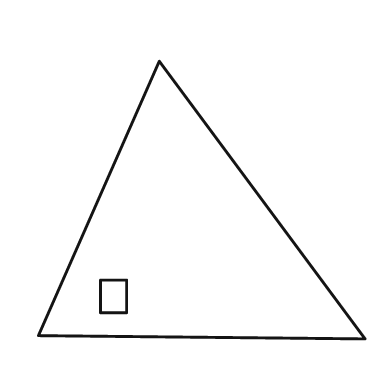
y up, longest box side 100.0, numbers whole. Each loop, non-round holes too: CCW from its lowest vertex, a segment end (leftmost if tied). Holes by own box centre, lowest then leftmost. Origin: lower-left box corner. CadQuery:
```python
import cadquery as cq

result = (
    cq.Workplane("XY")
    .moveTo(100.0, 0.0)
    .lineTo(37.0, 85.0)
    .lineTo(0.0, 1.0)
    .close()
    .moveTo(19.0, 8.0)
    .lineTo(27.0, 8.0)
    .lineTo(27.0, 18.0)
    .lineTo(19.0, 18.0)
    .close()
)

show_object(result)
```